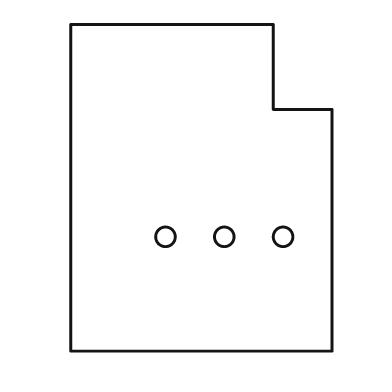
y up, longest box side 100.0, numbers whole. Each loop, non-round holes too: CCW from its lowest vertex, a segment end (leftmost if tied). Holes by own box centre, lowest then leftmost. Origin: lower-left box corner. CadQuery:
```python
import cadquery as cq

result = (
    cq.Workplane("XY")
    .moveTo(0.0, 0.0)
    .lineTo(80.0, 0.0)
    .lineTo(80.0, 74.0)
    .lineTo(62.0, 74.0)
    .lineTo(62.0, 100.0)
    .lineTo(0.0, 100.0)
    .close()
    .moveTo(29.0, 35.0)
    .circle(3.0)
    .moveTo(47.0, 35.0)
    .circle(3.0)
    .moveTo(65.0, 35.0)
    .circle(3.0)
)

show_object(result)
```